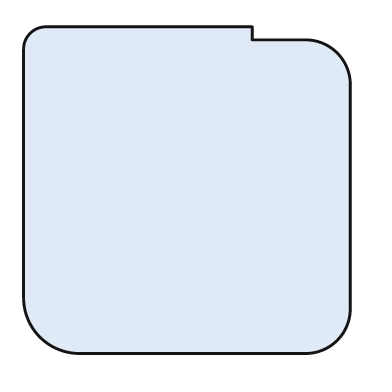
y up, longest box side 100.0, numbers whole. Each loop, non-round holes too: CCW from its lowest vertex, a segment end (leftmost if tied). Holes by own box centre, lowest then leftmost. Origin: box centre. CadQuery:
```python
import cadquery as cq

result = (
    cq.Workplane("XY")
    .moveTo(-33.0, -50.0)
    .lineTo(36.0, -50.0)
    .threePointArc((46.0, -46.0), (50.0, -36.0))
    .lineTo(50.0, 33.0)
    .threePointArc((46.0, 42.0), (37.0, 46.0))
    .lineTo(20.0, 46.0)
    .lineTo(20.0, 50.0)
    .lineTo(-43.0, 50.0)
    .threePointArc((-48.0, 48.0), (-50.0, 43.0))
    .lineTo(-50.0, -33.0)
    .threePointArc((-45.0, -45.0), (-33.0, -50.0))
    .close()
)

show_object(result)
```